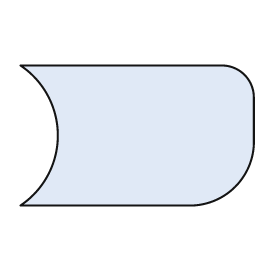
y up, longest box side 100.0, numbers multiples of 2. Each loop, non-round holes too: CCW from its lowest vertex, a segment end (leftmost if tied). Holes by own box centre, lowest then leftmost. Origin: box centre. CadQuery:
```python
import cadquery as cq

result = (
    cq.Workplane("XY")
    .moveTo(-50.0, -30.0)
    .lineTo(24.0, -30.0)
    .threePointArc((42.0, -22.0), (50.0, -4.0))
    .lineTo(50.0, 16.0)
    .threePointArc((46.0, 26.0), (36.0, 30.0))
    .lineTo(-50.0, 30.0)
    .threePointArc((-34.0, 0.0), (-50.0, -30.0))
    .close()
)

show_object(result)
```